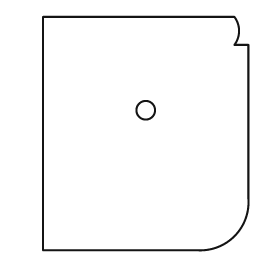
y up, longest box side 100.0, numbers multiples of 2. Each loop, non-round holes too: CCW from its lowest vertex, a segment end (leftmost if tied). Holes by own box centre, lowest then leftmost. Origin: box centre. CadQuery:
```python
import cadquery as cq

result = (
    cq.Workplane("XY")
    .moveTo(-44.0, -50.0)
    .lineTo(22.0, -50.0)
    .threePointArc((38.0, -44.0), (44.0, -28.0))
    .lineTo(44.0, 38.0)
    .lineTo(38.0, 38.0)
    .threePointArc((40.0, 44.0), (38.0, 50.0))
    .lineTo(-44.0, 50.0)
    .close()
    .moveTo(0.0, 10.0)
    .circle(4.0)
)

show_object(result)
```